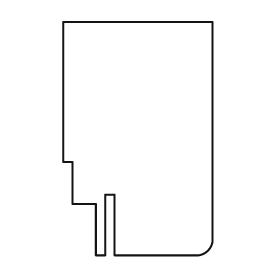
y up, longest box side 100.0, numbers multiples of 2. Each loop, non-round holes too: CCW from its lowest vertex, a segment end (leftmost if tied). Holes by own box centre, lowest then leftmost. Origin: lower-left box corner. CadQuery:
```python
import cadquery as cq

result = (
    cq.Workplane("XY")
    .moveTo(14.0, 0.0)
    .lineTo(18.0, 0.0)
    .lineTo(18.0, 26.0)
    .lineTo(22.0, 26.0)
    .lineTo(22.0, 0.0)
    .lineTo(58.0, 0.0)
    .threePointArc((62.0, 2.0), (64.0, 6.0))
    .lineTo(64.0, 100.0)
    .lineTo(0.0, 100.0)
    .lineTo(0.0, 40.0)
    .lineTo(4.0, 40.0)
    .lineTo(4.0, 22.0)
    .lineTo(14.0, 22.0)
    .close()
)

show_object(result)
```